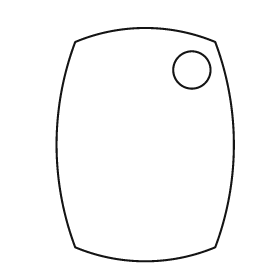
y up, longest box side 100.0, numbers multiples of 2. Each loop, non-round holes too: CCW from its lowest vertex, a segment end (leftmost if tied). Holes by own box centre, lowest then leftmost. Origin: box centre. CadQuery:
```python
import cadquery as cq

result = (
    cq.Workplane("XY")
    .moveTo(-30.0, -44.0)
    .threePointArc((0.0, -50.0), (30.0, -44.0))
    .threePointArc((38.0, 0.0), (30.0, 44.0))
    .threePointArc((0.0, 50.0), (-30.0, 44.0))
    .threePointArc((-38.0, 0.0), (-30.0, -44.0))
    .close()
    .moveTo(20.0, 32.0)
    .circle(8.0)
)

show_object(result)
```